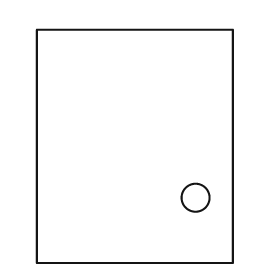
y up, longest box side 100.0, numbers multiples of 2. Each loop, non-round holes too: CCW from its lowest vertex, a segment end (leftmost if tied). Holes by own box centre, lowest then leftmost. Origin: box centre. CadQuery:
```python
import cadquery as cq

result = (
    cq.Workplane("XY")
    .moveTo(-42.0, -50.0)
    .lineTo(42.0, -50.0)
    .lineTo(42.0, 50.0)
    .lineTo(-42.0, 50.0)
    .close()
    .moveTo(26.0, -22.0)
    .circle(6.0)
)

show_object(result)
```